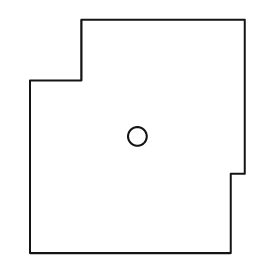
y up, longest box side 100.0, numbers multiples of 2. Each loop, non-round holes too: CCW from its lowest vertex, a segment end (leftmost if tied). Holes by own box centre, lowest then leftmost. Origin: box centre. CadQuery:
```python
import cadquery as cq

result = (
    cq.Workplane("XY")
    .moveTo(-46.0, -50.0)
    .lineTo(40.0, -50.0)
    .lineTo(40.0, -16.0)
    .lineTo(46.0, -16.0)
    .lineTo(46.0, 50.0)
    .lineTo(-24.0, 50.0)
    .lineTo(-24.0, 24.0)
    .lineTo(-46.0, 24.0)
    .close()
    .moveTo(0.0, 0.0)
    .circle(4.0)
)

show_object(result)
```